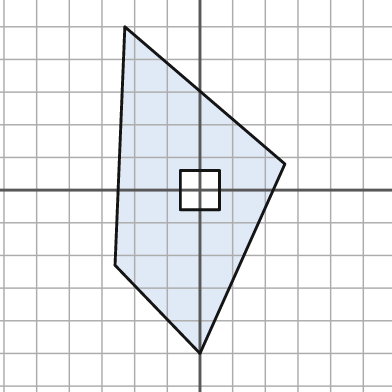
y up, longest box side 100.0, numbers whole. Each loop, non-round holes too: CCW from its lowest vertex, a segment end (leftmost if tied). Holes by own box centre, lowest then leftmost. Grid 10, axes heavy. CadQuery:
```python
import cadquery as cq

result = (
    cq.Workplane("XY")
    .moveTo(0.0, -50.0)
    .lineTo(26.0, 8.0)
    .lineTo(-23.0, 50.0)
    .lineTo(-26.0, -23.0)
    .close()
    .moveTo(-6.0, -6.0)
    .lineTo(6.0, -6.0)
    .lineTo(6.0, 6.0)
    .lineTo(-6.0, 6.0)
    .close()
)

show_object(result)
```